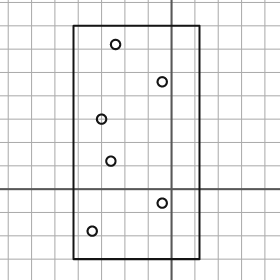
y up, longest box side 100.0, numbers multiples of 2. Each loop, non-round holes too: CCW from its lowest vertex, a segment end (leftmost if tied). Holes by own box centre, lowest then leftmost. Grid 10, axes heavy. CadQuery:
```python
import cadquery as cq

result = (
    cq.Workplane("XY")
    .moveTo(-42.0, -30.0)
    .lineTo(12.0, -30.0)
    .lineTo(12.0, 70.0)
    .lineTo(-42.0, 70.0)
    .close()
    .moveTo(-34.0, -18.0)
    .circle(2.0)
    .moveTo(-4.0, -6.0)
    .circle(2.0)
    .moveTo(-26.0, 12.0)
    .circle(2.0)
    .moveTo(-30.0, 30.0)
    .circle(2.0)
    .moveTo(-4.0, 46.0)
    .circle(2.0)
    .moveTo(-24.0, 62.0)
    .circle(2.0)
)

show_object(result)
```